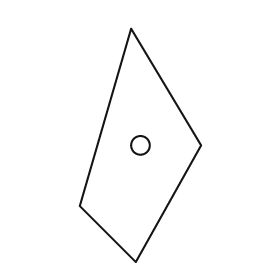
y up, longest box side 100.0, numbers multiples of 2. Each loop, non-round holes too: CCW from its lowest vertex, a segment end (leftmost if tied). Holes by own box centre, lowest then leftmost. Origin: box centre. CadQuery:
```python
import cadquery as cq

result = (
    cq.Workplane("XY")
    .moveTo(-2.0, -50.0)
    .lineTo(26.0, 0.0)
    .lineTo(-4.0, 50.0)
    .lineTo(-26.0, -26.0)
    .close()
    .moveTo(0.0, 0.0)
    .circle(4.0)
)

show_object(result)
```